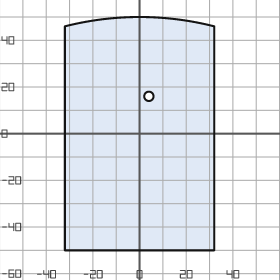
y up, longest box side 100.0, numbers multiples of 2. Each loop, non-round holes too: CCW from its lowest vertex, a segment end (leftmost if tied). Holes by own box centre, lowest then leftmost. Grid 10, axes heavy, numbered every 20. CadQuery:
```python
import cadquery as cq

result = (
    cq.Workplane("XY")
    .moveTo(-32.0, -50.0)
    .lineTo(32.0, -50.0)
    .lineTo(32.0, 46.0)
    .threePointArc((0.0, 50.0), (-32.0, 46.0))
    .close()
    .moveTo(4.0, 16.0)
    .circle(2.0)
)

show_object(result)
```